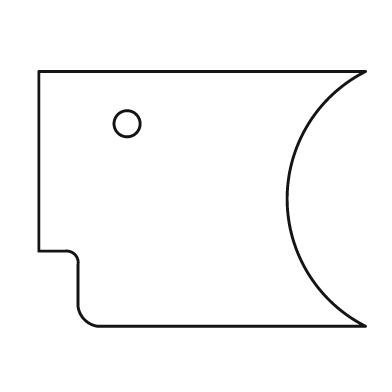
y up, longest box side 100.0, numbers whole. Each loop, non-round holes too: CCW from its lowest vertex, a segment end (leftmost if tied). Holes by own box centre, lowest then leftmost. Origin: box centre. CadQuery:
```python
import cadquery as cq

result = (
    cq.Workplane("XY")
    .moveTo(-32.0, -39.0)
    .lineTo(50.0, -39.0)
    .threePointArc((26.0, 0.0), (50.0, 39.0))
    .lineTo(-50.0, 39.0)
    .lineTo(-50.0, -16.0)
    .lineTo(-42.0, -16.0)
    .threePointArc((-39.0, -17.0), (-38.0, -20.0))
    .lineTo(-38.0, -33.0)
    .threePointArc((-36.0, -37.0), (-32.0, -39.0))
    .close()
    .moveTo(-23.0, 23.0)
    .circle(4.0)
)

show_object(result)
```